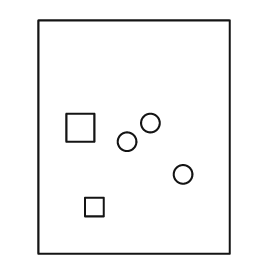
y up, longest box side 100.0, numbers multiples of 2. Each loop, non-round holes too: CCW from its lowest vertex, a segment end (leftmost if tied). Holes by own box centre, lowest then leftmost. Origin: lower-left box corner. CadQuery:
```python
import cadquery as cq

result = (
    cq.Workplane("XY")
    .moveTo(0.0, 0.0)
    .lineTo(82.0, 0.0)
    .lineTo(82.0, 100.0)
    .lineTo(0.0, 100.0)
    .close()
    .moveTo(20.0, 16.0)
    .lineTo(28.0, 16.0)
    .lineTo(28.0, 24.0)
    .lineTo(20.0, 24.0)
    .close()
    .moveTo(62.0, 34.0)
    .circle(4.0)
    .moveTo(38.0, 48.0)
    .circle(4.0)
    .moveTo(12.0, 48.0)
    .lineTo(24.0, 48.0)
    .lineTo(24.0, 60.0)
    .lineTo(12.0, 60.0)
    .close()
    .moveTo(48.0, 56.0)
    .circle(4.0)
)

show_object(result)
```